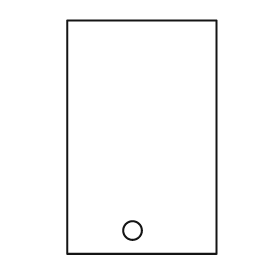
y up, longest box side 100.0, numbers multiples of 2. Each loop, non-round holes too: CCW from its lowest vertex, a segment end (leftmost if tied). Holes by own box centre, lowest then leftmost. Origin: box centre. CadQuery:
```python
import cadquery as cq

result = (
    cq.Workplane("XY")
    .moveTo(-32.0, -50.0)
    .lineTo(32.0, -50.0)
    .lineTo(32.0, 50.0)
    .lineTo(-32.0, 50.0)
    .close()
    .moveTo(-4.0, -40.0)
    .circle(4.0)
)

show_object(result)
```